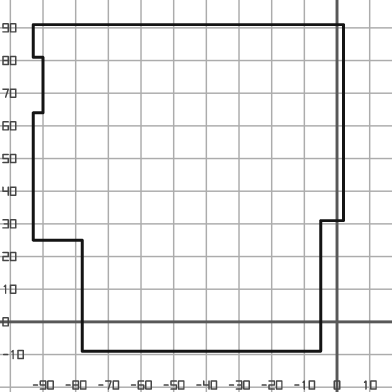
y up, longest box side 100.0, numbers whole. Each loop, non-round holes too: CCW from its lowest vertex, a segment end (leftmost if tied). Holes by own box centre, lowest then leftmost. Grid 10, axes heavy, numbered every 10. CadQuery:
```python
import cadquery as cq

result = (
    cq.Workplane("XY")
    .moveTo(-78.0, -9.0)
    .lineTo(-5.0, -9.0)
    .lineTo(-5.0, 31.0)
    .lineTo(2.0, 31.0)
    .lineTo(2.0, 91.0)
    .lineTo(-93.0, 91.0)
    .lineTo(-93.0, 81.0)
    .lineTo(-90.0, 81.0)
    .lineTo(-90.0, 64.0)
    .lineTo(-93.0, 64.0)
    .lineTo(-93.0, 25.0)
    .lineTo(-78.0, 25.0)
    .close()
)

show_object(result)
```